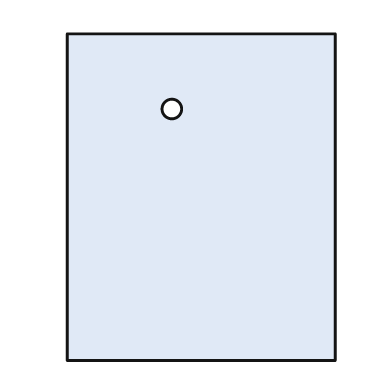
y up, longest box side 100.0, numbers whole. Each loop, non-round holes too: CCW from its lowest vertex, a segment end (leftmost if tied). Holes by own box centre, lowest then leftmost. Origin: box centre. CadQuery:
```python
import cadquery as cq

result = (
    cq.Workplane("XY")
    .moveTo(-41.0, -50.0)
    .lineTo(41.0, -50.0)
    .lineTo(41.0, 50.0)
    .lineTo(-41.0, 50.0)
    .close()
    .moveTo(-9.0, 27.0)
    .circle(3.0)
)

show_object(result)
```